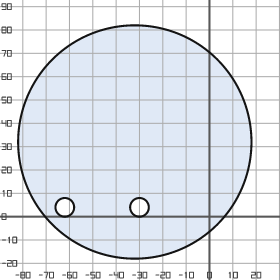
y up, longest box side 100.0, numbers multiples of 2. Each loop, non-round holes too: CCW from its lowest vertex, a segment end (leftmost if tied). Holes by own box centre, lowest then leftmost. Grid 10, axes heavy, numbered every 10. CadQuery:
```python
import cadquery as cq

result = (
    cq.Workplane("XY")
    .moveTo(-32.0, 32.0)
    .circle(50.0)
    .moveTo(-62.0, 4.0)
    .circle(4.0)
    .moveTo(-30.0, 4.0)
    .circle(4.0)
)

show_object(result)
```